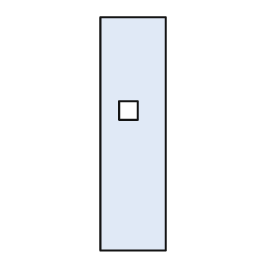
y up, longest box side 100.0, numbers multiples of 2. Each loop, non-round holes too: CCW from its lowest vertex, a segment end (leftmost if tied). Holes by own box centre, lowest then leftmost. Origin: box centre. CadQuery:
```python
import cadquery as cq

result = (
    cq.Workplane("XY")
    .moveTo(-14.0, -50.0)
    .lineTo(14.0, -50.0)
    .lineTo(14.0, 50.0)
    .lineTo(-14.0, 50.0)
    .close()
    .moveTo(-6.0, 6.0)
    .lineTo(2.0, 6.0)
    .lineTo(2.0, 14.0)
    .lineTo(-6.0, 14.0)
    .close()
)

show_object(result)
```